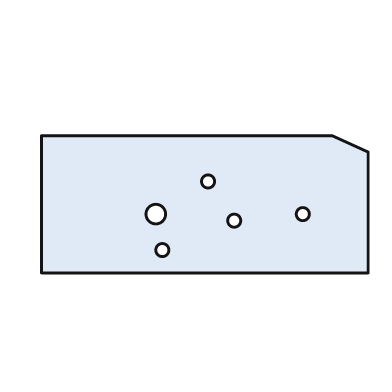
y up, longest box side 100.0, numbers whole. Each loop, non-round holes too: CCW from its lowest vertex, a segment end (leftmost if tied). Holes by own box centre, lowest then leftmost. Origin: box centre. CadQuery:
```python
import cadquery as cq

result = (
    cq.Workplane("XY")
    .moveTo(-50.0, -21.0)
    .lineTo(50.0, -21.0)
    .lineTo(50.0, 16.0)
    .lineTo(39.0, 21.0)
    .lineTo(-50.0, 21.0)
    .close()
    .moveTo(-13.0, -14.0)
    .circle(2.0)
    .moveTo(9.0, -5.0)
    .circle(2.0)
    .moveTo(-15.0, -3.0)
    .circle(3.0)
    .moveTo(30.0, -3.0)
    .circle(2.0)
    .moveTo(1.0, 7.0)
    .circle(2.0)
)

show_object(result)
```